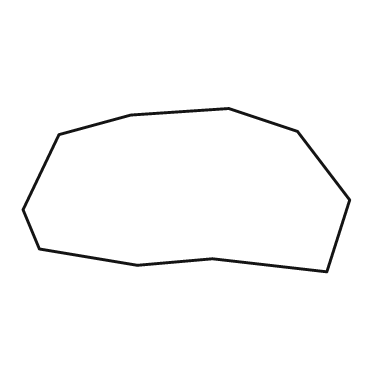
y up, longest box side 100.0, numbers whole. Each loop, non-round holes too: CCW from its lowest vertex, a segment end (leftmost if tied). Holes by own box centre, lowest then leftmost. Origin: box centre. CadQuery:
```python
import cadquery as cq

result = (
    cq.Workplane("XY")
    .moveTo(43.0, -25.0)
    .lineTo(50.0, -3.0)
    .lineTo(34.0, 18.0)
    .lineTo(13.0, 25.0)
    .lineTo(-17.0, 23.0)
    .lineTo(-39.0, 17.0)
    .lineTo(-50.0, -6.0)
    .lineTo(-45.0, -18.0)
    .lineTo(-15.0, -23.0)
    .lineTo(8.0, -21.0)
    .close()
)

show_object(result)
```